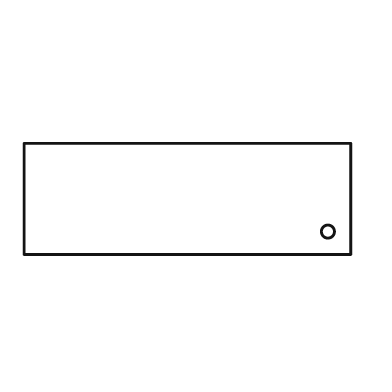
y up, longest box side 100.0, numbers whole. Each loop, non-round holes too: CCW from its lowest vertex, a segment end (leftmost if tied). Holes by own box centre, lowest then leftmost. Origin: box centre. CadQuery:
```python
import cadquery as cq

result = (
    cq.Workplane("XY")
    .moveTo(-50.0, -17.0)
    .lineTo(50.0, -17.0)
    .lineTo(50.0, 17.0)
    .lineTo(-50.0, 17.0)
    .close()
    .moveTo(43.0, -10.0)
    .circle(2.0)
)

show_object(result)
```